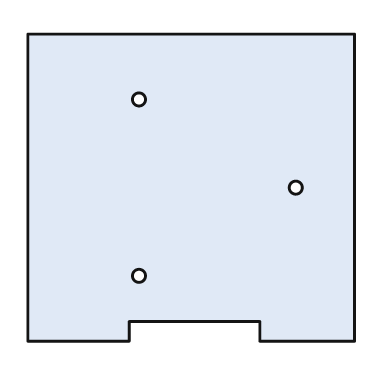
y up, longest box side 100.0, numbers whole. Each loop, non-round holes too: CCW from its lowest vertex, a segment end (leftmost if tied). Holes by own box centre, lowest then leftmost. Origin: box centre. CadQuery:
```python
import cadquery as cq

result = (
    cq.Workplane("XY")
    .moveTo(-50.0, -47.0)
    .lineTo(-19.0, -47.0)
    .lineTo(-19.0, -41.0)
    .lineTo(21.0, -41.0)
    .lineTo(21.0, -47.0)
    .lineTo(50.0, -47.0)
    .lineTo(50.0, 47.0)
    .lineTo(-50.0, 47.0)
    .close()
    .moveTo(-16.0, -27.0)
    .circle(2.0)
    .moveTo(32.0, 0.0)
    .circle(2.0)
    .moveTo(-16.0, 27.0)
    .circle(2.0)
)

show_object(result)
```